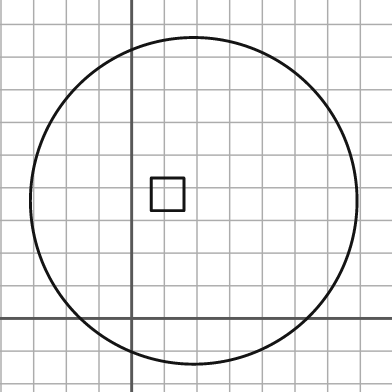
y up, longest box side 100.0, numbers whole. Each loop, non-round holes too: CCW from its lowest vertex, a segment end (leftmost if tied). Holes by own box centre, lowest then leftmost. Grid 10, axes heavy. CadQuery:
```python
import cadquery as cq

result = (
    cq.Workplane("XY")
    .moveTo(19.0, 36.0)
    .circle(50.0)
    .moveTo(6.0, 33.0)
    .lineTo(16.0, 33.0)
    .lineTo(16.0, 43.0)
    .lineTo(6.0, 43.0)
    .close()
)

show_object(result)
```